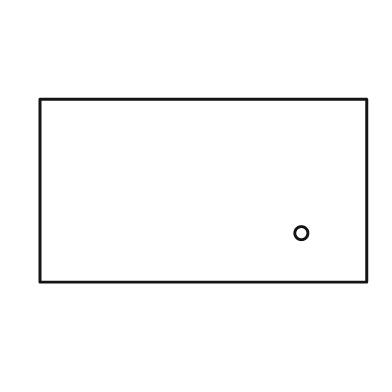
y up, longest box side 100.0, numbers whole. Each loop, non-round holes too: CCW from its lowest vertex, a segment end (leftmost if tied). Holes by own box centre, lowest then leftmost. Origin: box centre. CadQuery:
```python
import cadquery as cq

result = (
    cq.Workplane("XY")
    .moveTo(-50.0, -28.0)
    .lineTo(50.0, -28.0)
    .lineTo(50.0, 28.0)
    .lineTo(-50.0, 28.0)
    .close()
    .moveTo(30.0, -13.0)
    .circle(2.0)
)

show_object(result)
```